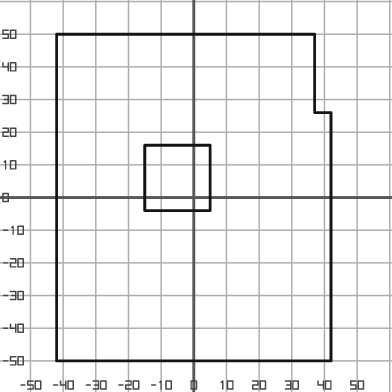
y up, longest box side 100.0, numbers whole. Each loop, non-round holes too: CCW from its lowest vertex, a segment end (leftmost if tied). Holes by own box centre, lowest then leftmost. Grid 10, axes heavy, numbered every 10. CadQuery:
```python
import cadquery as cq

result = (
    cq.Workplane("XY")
    .moveTo(-42.0, -50.0)
    .lineTo(42.0, -50.0)
    .lineTo(42.0, 26.0)
    .lineTo(37.0, 26.0)
    .lineTo(37.0, 50.0)
    .lineTo(-42.0, 50.0)
    .close()
    .moveTo(-15.0, -4.0)
    .lineTo(5.0, -4.0)
    .lineTo(5.0, 16.0)
    .lineTo(-15.0, 16.0)
    .close()
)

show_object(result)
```